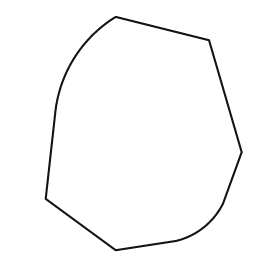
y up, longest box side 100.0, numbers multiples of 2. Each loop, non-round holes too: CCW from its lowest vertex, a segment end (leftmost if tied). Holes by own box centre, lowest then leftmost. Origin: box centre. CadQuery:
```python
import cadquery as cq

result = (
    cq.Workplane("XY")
    .moveTo(-12.0, -50.0)
    .lineTo(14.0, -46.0)
    .threePointArc((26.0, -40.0), (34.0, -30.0))
    .lineTo(42.0, -8.0)
    .lineTo(28.0, 40.0)
    .lineTo(-12.0, 50.0)
    .threePointArc((-30.0, 32.0), (-38.0, 8.0))
    .lineTo(-42.0, -28.0)
    .close()
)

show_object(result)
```